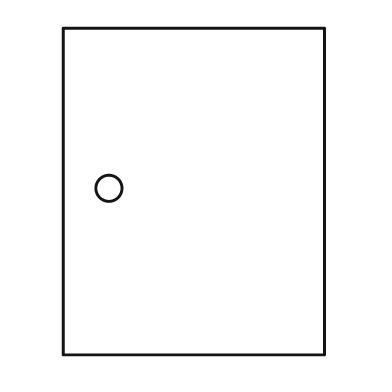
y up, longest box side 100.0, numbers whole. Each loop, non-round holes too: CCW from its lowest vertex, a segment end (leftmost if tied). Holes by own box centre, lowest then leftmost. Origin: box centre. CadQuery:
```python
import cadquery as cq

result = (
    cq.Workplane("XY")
    .moveTo(-40.0, -50.0)
    .lineTo(40.0, -50.0)
    .lineTo(40.0, 50.0)
    .lineTo(-40.0, 50.0)
    .close()
    .moveTo(-26.0, 1.0)
    .circle(4.0)
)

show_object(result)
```